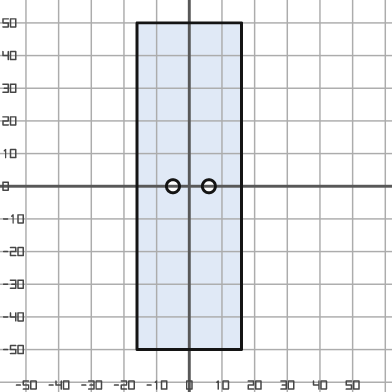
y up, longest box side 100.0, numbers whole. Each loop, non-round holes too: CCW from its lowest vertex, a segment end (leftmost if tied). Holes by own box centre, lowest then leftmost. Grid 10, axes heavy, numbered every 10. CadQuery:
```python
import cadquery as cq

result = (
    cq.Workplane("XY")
    .moveTo(-16.0, -50.0)
    .lineTo(16.0, -50.0)
    .lineTo(16.0, 50.0)
    .lineTo(-16.0, 50.0)
    .close()
    .moveTo(-5.0, 0.0)
    .circle(2.0)
    .moveTo(6.0, 0.0)
    .circle(2.0)
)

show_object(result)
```